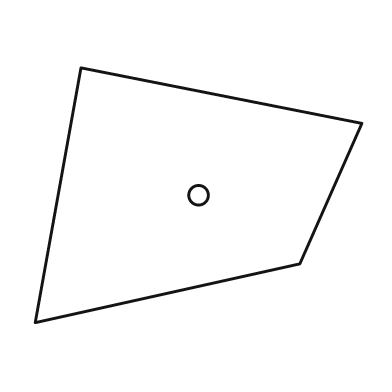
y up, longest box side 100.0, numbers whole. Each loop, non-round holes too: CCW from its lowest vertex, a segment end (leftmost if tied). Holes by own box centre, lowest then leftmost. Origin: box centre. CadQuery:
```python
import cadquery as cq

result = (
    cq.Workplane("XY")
    .moveTo(-50.0, -39.0)
    .lineTo(31.0, -21.0)
    .lineTo(50.0, 22.0)
    .lineTo(-36.0, 39.0)
    .close()
    .moveTo(0.0, 0.0)
    .circle(3.0)
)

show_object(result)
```